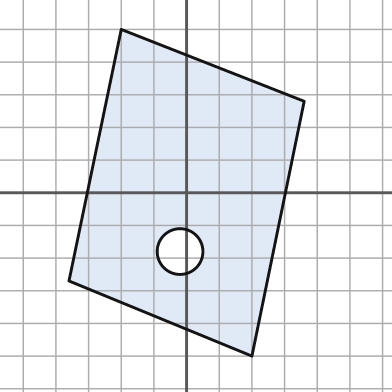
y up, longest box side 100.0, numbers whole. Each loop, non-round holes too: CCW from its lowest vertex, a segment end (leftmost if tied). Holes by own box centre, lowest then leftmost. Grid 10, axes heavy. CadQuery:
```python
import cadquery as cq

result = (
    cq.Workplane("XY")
    .moveTo(20.0, -50.0)
    .lineTo(36.0, 28.0)
    .lineTo(-20.0, 50.0)
    .lineTo(-36.0, -27.0)
    .close()
    .moveTo(-2.0, -18.0)
    .circle(7.0)
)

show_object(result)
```